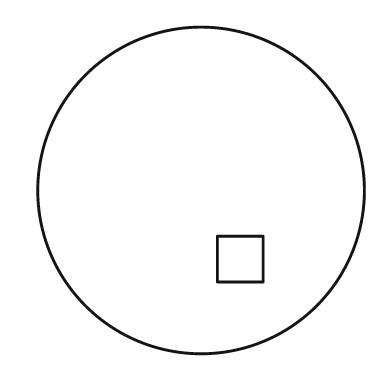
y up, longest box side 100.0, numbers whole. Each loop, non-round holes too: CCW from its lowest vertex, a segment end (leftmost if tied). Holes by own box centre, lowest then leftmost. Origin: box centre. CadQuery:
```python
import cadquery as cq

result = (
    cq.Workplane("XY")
    .moveTo(0.0, 0.0)
    .circle(50.0)
    .moveTo(5.0, -28.0)
    .lineTo(19.0, -28.0)
    .lineTo(19.0, -14.0)
    .lineTo(5.0, -14.0)
    .close()
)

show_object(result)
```